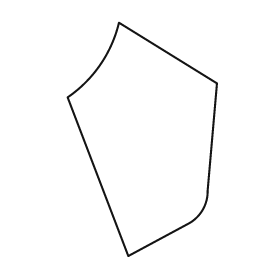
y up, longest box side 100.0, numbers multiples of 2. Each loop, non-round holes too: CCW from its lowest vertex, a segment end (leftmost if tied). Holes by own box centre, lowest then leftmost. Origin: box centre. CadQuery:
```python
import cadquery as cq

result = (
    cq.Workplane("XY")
    .moveTo(-6.0, -50.0)
    .lineTo(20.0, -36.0)
    .threePointArc((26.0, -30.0), (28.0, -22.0))
    .lineTo(32.0, 24.0)
    .lineTo(-10.0, 50.0)
    .threePointArc((-18.0, 32.0), (-32.0, 18.0))
    .close()
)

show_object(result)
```